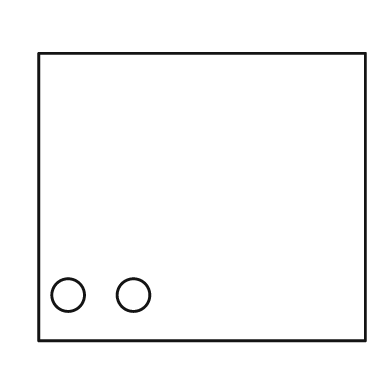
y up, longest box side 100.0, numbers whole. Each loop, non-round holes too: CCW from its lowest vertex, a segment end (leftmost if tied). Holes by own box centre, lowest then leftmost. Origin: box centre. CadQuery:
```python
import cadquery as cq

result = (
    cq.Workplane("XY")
    .moveTo(-50.0, -44.0)
    .lineTo(50.0, -44.0)
    .lineTo(50.0, 44.0)
    .lineTo(-50.0, 44.0)
    .close()
    .moveTo(-41.0, -30.0)
    .circle(5.0)
    .moveTo(-21.0, -30.0)
    .circle(5.0)
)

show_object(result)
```